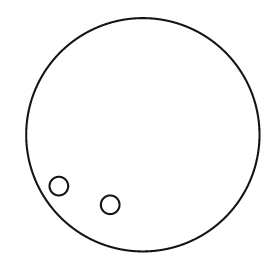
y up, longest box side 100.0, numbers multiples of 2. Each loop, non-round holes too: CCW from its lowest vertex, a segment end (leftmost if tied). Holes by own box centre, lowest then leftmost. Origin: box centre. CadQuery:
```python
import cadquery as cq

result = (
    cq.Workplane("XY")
    .moveTo(0.0, 0.0)
    .circle(50.0)
    .moveTo(-14.0, -30.0)
    .circle(4.0)
    .moveTo(-36.0, -22.0)
    .circle(4.0)
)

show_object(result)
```